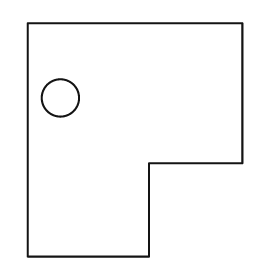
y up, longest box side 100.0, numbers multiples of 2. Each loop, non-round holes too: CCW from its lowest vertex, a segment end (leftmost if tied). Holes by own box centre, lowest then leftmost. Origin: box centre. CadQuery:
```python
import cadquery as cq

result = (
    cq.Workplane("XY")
    .moveTo(-46.0, -50.0)
    .lineTo(6.0, -50.0)
    .lineTo(6.0, -10.0)
    .lineTo(46.0, -10.0)
    .lineTo(46.0, 50.0)
    .lineTo(-46.0, 50.0)
    .close()
    .moveTo(-32.0, 18.0)
    .circle(8.0)
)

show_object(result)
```